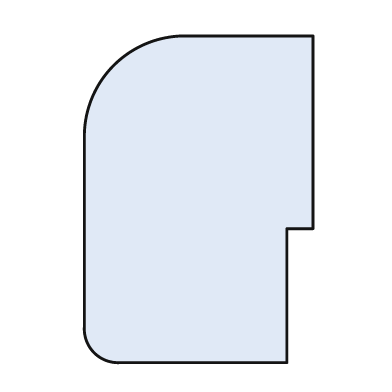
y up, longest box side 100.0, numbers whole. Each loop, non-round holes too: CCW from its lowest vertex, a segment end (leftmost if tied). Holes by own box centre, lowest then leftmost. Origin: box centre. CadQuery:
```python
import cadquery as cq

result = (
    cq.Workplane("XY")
    .moveTo(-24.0, -50.0)
    .lineTo(27.0, -50.0)
    .lineTo(27.0, -9.0)
    .lineTo(35.0, -9.0)
    .lineTo(35.0, 50.0)
    .lineTo(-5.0, 50.0)
    .threePointArc((-26.0, 41.0), (-35.0, 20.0))
    .lineTo(-35.0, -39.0)
    .threePointArc((-32.0, -47.0), (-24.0, -50.0))
    .close()
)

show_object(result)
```